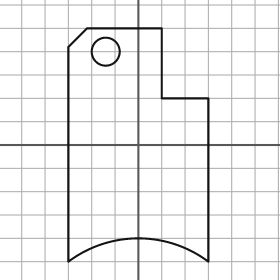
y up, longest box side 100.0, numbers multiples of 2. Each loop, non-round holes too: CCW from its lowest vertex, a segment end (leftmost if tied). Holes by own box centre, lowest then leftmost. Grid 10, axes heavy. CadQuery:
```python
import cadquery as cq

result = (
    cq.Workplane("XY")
    .moveTo(-30.0, -50.0)
    .threePointArc((0.0, -40.0), (30.0, -50.0))
    .lineTo(30.0, 20.0)
    .lineTo(10.0, 20.0)
    .lineTo(10.0, 50.0)
    .lineTo(-22.0, 50.0)
    .lineTo(-30.0, 42.0)
    .close()
    .moveTo(-14.0, 40.0)
    .circle(6.0)
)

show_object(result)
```